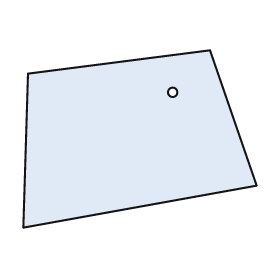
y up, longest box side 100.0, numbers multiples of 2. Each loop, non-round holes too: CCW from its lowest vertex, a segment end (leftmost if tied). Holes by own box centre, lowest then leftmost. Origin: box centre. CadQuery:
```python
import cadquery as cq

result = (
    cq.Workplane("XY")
    .moveTo(-50.0, -38.0)
    .lineTo(50.0, -20.0)
    .lineTo(30.0, 38.0)
    .lineTo(-48.0, 28.0)
    .close()
    .moveTo(14.0, 20.0)
    .circle(2.0)
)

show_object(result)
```